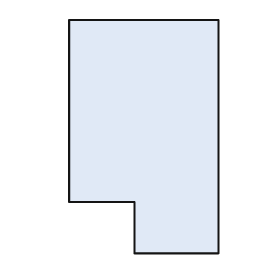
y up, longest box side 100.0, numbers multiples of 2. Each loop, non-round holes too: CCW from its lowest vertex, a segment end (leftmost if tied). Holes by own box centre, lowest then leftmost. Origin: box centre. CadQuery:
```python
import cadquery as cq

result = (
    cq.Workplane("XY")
    .moveTo(-4.0, -50.0)
    .lineTo(32.0, -50.0)
    .lineTo(32.0, 50.0)
    .lineTo(-32.0, 50.0)
    .lineTo(-32.0, -28.0)
    .lineTo(-4.0, -28.0)
    .close()
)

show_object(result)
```